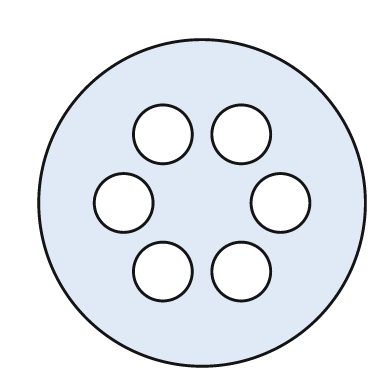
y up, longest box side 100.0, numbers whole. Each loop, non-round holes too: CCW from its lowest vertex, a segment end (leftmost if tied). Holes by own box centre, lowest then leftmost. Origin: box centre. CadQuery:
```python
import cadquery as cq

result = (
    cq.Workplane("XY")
    .moveTo(0.0, 0.0)
    .circle(50.0)
    .moveTo(-12.0, -21.0)
    .circle(9.0)
    .moveTo(12.0, -21.0)
    .circle(9.0)
    .moveTo(-24.0, 0.0)
    .circle(9.0)
    .moveTo(24.0, 0.0)
    .circle(9.0)
    .moveTo(-12.0, 21.0)
    .circle(9.0)
    .moveTo(12.0, 21.0)
    .circle(9.0)
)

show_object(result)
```